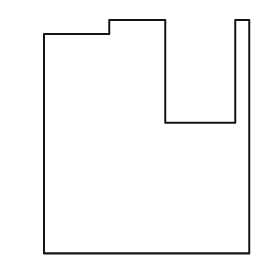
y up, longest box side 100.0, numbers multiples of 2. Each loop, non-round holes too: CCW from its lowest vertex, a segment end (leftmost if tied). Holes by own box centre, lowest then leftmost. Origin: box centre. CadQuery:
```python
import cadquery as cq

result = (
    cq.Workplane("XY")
    .moveTo(-44.0, -50.0)
    .lineTo(44.0, -50.0)
    .lineTo(44.0, 50.0)
    .lineTo(38.0, 50.0)
    .lineTo(38.0, 6.0)
    .lineTo(8.0, 6.0)
    .lineTo(8.0, 50.0)
    .lineTo(-16.0, 50.0)
    .lineTo(-16.0, 44.0)
    .lineTo(-44.0, 44.0)
    .close()
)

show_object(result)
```